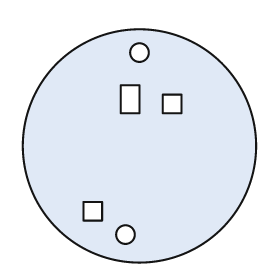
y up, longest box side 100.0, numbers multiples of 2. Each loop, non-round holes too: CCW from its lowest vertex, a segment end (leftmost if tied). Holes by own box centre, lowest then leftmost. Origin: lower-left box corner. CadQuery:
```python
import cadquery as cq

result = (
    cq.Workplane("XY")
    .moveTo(50.0, 50.0)
    .circle(50.0)
    .moveTo(44.0, 12.0)
    .circle(4.0)
    .moveTo(26.0, 18.0)
    .lineTo(34.0, 18.0)
    .lineTo(34.0, 26.0)
    .lineTo(26.0, 26.0)
    .close()
    .moveTo(60.0, 64.0)
    .lineTo(68.0, 64.0)
    .lineTo(68.0, 72.0)
    .lineTo(60.0, 72.0)
    .close()
    .moveTo(42.0, 64.0)
    .lineTo(50.0, 64.0)
    .lineTo(50.0, 76.0)
    .lineTo(42.0, 76.0)
    .close()
    .moveTo(50.0, 90.0)
    .circle(4.0)
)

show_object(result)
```